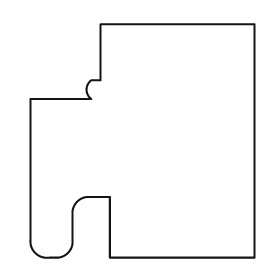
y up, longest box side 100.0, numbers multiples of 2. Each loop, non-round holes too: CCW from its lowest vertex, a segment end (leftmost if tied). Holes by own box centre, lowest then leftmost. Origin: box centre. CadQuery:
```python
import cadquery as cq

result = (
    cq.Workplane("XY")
    .moveTo(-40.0, -50.0)
    .lineTo(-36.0, -50.0)
    .threePointArc((-32.0, -48.0), (-30.0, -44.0))
    .lineTo(-30.0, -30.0)
    .threePointArc((-28.0, -26.0), (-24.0, -24.0))
    .lineTo(-14.0, -24.0)
    .lineTo(-14.0, -50.0)
    .lineTo(48.0, -50.0)
    .lineTo(48.0, 50.0)
    .lineTo(-18.0, 50.0)
    .lineTo(-18.0, 26.0)
    .lineTo(-22.0, 26.0)
    .threePointArc((-24.0, 22.0), (-22.0, 18.0))
    .lineTo(-48.0, 18.0)
    .lineTo(-48.0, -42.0)
    .threePointArc((-46.0, -48.0), (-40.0, -50.0))
    .close()
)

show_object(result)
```